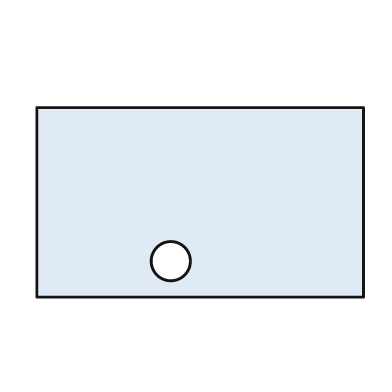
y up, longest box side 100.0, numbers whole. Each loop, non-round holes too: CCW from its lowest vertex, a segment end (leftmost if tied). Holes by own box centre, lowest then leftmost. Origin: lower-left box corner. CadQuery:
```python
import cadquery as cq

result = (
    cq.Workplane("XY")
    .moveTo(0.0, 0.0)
    .lineTo(100.0, 0.0)
    .lineTo(100.0, 58.0)
    .lineTo(0.0, 58.0)
    .close()
    .moveTo(41.0, 11.0)
    .circle(6.0)
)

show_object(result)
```